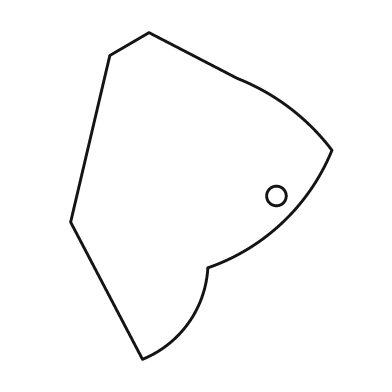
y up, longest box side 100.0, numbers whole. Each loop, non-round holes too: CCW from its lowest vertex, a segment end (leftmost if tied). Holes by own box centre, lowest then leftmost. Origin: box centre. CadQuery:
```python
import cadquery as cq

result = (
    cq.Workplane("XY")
    .moveTo(-18.0, -50.0)
    .threePointArc((-4.0, -39.0), (2.0, -22.0))
    .threePointArc((25.0, -8.0), (40.0, 14.0))
    .threePointArc((27.0, 27.0), (11.0, 36.0))
    .lineTo(-16.0, 50.0)
    .lineTo(-28.0, 43.0)
    .lineTo(-40.0, -8.0)
    .close()
    .moveTo(23.0, 0.0)
    .circle(3.0)
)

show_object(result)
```